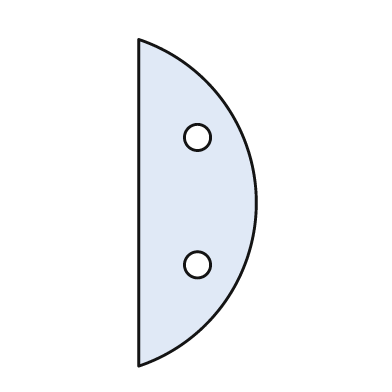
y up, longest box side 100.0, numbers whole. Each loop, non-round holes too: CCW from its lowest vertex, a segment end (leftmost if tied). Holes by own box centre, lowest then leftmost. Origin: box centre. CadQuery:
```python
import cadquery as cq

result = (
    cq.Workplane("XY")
    .moveTo(-18.0, -50.0)
    .threePointArc((18.0, 0.0), (-18.0, 50.0))
    .close()
    .moveTo(0.0, -19.0)
    .circle(4.0)
    .moveTo(0.0, 20.0)
    .circle(4.0)
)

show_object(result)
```